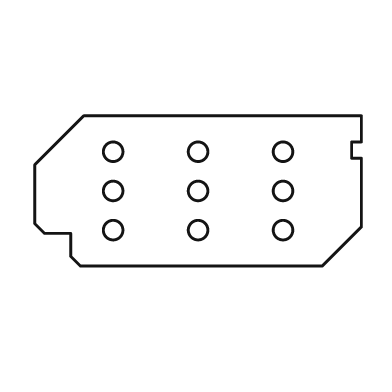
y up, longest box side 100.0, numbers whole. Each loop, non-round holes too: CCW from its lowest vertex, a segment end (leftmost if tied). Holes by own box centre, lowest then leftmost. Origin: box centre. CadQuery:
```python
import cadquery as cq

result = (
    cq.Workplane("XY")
    .moveTo(-36.0, -23.0)
    .lineTo(38.0, -23.0)
    .lineTo(50.0, -11.0)
    .lineTo(50.0, 10.0)
    .lineTo(47.0, 10.0)
    .lineTo(47.0, 15.0)
    .lineTo(50.0, 15.0)
    .lineTo(50.0, 23.0)
    .lineTo(-35.0, 23.0)
    .lineTo(-50.0, 8.0)
    .lineTo(-50.0, -10.0)
    .lineTo(-47.0, -13.0)
    .lineTo(-39.0, -13.0)
    .lineTo(-39.0, -20.0)
    .close()
    .moveTo(-26.0, -12.0)
    .circle(3.0)
    .moveTo(0.0, -12.0)
    .circle(3.0)
    .moveTo(26.0, -12.0)
    .circle(3.0)
    .moveTo(-26.0, 0.0)
    .circle(3.0)
    .moveTo(0.0, 0.0)
    .circle(3.0)
    .moveTo(26.0, 0.0)
    .circle(3.0)
    .moveTo(-26.0, 12.0)
    .circle(3.0)
    .moveTo(0.0, 12.0)
    .circle(3.0)
    .moveTo(26.0, 12.0)
    .circle(3.0)
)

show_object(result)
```